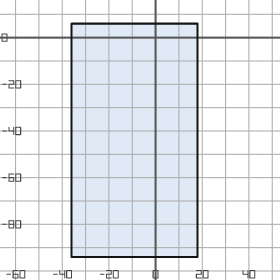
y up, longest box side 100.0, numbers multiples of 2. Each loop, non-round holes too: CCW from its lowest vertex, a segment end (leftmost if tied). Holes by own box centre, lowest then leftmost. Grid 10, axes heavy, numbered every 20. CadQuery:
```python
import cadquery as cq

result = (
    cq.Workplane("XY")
    .moveTo(-36.0, -94.0)
    .lineTo(18.0, -94.0)
    .lineTo(18.0, 6.0)
    .lineTo(-36.0, 6.0)
    .close()
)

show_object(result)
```